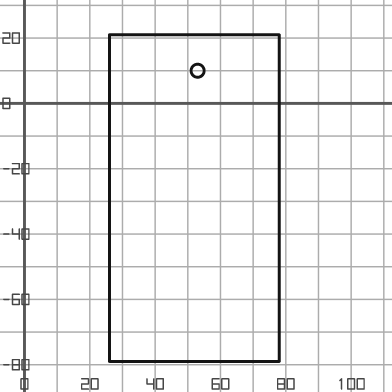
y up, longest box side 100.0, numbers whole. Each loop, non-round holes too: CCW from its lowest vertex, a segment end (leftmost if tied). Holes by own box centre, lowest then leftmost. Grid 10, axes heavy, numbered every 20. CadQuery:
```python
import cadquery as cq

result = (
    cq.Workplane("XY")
    .moveTo(26.0, -79.0)
    .lineTo(78.0, -79.0)
    .lineTo(78.0, 21.0)
    .lineTo(26.0, 21.0)
    .close()
    .moveTo(53.0, 10.0)
    .circle(2.0)
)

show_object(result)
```